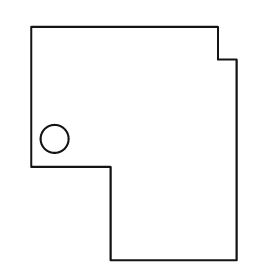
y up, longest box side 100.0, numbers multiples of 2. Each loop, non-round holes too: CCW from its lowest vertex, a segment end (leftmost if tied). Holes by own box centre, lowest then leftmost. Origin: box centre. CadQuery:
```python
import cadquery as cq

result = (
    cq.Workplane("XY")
    .moveTo(-10.0, -50.0)
    .lineTo(44.0, -50.0)
    .lineTo(44.0, 36.0)
    .lineTo(36.0, 36.0)
    .lineTo(36.0, 50.0)
    .lineTo(-44.0, 50.0)
    .lineTo(-44.0, -10.0)
    .lineTo(-10.0, -10.0)
    .close()
    .moveTo(-34.0, 2.0)
    .circle(6.0)
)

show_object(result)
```